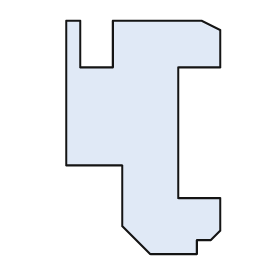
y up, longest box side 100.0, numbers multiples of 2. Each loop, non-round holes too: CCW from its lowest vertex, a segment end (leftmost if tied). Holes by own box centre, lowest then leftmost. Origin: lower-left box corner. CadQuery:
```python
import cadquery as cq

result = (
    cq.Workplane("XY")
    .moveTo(36.0, 0.0)
    .lineTo(56.0, 0.0)
    .lineTo(56.0, 6.0)
    .lineTo(62.0, 6.0)
    .lineTo(66.0, 10.0)
    .lineTo(66.0, 24.0)
    .lineTo(48.0, 24.0)
    .lineTo(48.0, 80.0)
    .lineTo(66.0, 80.0)
    .lineTo(66.0, 96.0)
    .lineTo(58.0, 100.0)
    .lineTo(20.0, 100.0)
    .lineTo(20.0, 80.0)
    .lineTo(6.0, 80.0)
    .lineTo(6.0, 100.0)
    .lineTo(0.0, 100.0)
    .lineTo(0.0, 38.0)
    .lineTo(24.0, 38.0)
    .lineTo(24.0, 12.0)
    .close()
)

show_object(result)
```